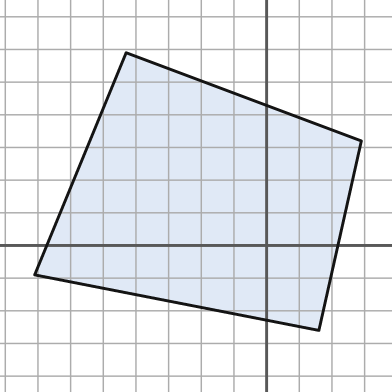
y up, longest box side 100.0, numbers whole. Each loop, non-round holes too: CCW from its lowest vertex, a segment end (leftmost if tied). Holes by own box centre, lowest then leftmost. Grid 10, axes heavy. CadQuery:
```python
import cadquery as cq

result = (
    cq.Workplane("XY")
    .moveTo(16.0, -26.0)
    .lineTo(29.0, 32.0)
    .lineTo(-43.0, 59.0)
    .lineTo(-71.0, -9.0)
    .close()
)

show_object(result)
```